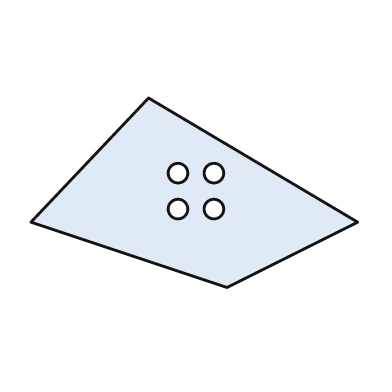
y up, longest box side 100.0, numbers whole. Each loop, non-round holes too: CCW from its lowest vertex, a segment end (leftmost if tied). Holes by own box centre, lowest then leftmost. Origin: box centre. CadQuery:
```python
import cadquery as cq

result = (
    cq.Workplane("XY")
    .moveTo(10.0, -29.0)
    .lineTo(50.0, -9.0)
    .lineTo(-14.0, 29.0)
    .lineTo(-50.0, -9.0)
    .close()
    .moveTo(-5.0, -5.0)
    .circle(3.0)
    .moveTo(6.0, -5.0)
    .circle(3.0)
    .moveTo(-5.0, 6.0)
    .circle(3.0)
    .moveTo(6.0, 6.0)
    .circle(3.0)
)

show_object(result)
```